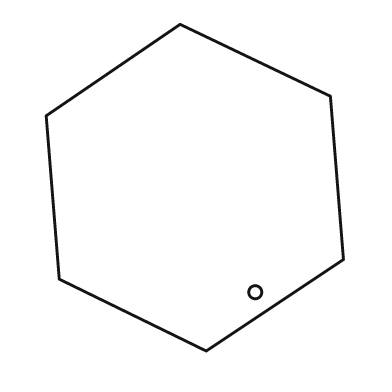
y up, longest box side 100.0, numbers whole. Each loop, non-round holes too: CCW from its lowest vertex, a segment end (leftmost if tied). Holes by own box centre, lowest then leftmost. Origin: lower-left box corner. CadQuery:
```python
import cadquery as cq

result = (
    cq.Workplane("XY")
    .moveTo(49.0, 0.0)
    .lineTo(91.0, 28.0)
    .lineTo(87.0, 78.0)
    .lineTo(41.0, 100.0)
    .lineTo(0.0, 72.0)
    .lineTo(4.0, 22.0)
    .close()
    .moveTo(64.0, 18.0)
    .circle(2.0)
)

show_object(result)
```